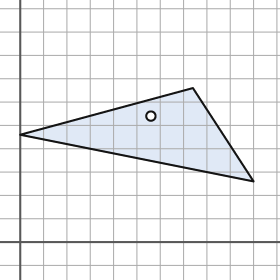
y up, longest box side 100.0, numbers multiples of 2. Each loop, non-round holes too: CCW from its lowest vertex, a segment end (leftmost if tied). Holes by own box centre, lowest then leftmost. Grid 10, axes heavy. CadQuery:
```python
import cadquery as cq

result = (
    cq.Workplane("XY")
    .moveTo(100.0, 26.0)
    .lineTo(74.0, 66.0)
    .lineTo(0.0, 46.0)
    .close()
    .moveTo(56.0, 54.0)
    .circle(2.0)
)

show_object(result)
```